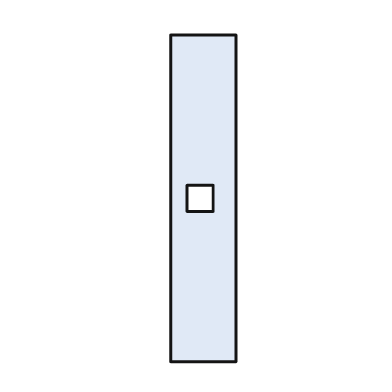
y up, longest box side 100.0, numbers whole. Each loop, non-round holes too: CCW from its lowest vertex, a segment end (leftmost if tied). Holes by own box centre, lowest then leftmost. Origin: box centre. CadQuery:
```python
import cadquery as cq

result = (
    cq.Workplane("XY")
    .moveTo(-10.0, -50.0)
    .lineTo(10.0, -50.0)
    .lineTo(10.0, 50.0)
    .lineTo(-10.0, 50.0)
    .close()
    .moveTo(-5.0, -4.0)
    .lineTo(3.0, -4.0)
    .lineTo(3.0, 4.0)
    .lineTo(-5.0, 4.0)
    .close()
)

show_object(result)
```